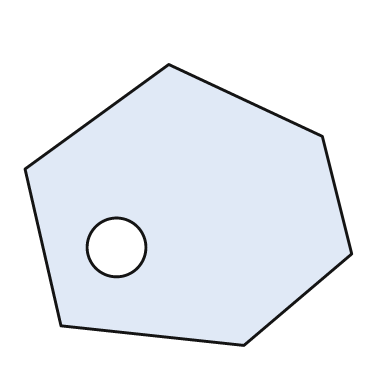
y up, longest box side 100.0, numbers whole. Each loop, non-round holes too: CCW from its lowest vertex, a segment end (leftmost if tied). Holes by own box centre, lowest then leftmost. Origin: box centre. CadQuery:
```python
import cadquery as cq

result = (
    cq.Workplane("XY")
    .moveTo(17.0, -43.0)
    .lineTo(50.0, -15.0)
    .lineTo(41.0, 21.0)
    .lineTo(-6.0, 43.0)
    .lineTo(-50.0, 11.0)
    .lineTo(-39.0, -37.0)
    .close()
    .moveTo(-22.0, -13.0)
    .circle(9.0)
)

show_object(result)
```